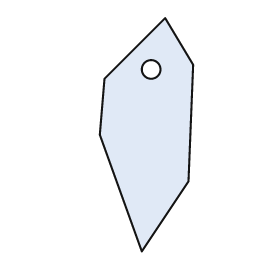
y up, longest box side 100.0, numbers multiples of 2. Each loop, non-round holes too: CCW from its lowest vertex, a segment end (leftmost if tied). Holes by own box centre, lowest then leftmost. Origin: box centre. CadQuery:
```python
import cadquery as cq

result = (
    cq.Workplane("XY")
    .moveTo(-2.0, -50.0)
    .lineTo(18.0, -20.0)
    .lineTo(20.0, 30.0)
    .lineTo(8.0, 50.0)
    .lineTo(-18.0, 24.0)
    .lineTo(-20.0, 0.0)
    .close()
    .moveTo(2.0, 28.0)
    .circle(4.0)
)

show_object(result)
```